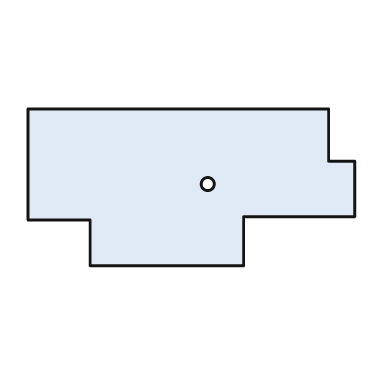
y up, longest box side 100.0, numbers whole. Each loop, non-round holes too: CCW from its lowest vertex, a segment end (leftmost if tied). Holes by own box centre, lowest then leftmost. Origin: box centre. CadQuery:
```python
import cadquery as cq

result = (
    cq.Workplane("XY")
    .moveTo(-31.0, -24.0)
    .lineTo(16.0, -24.0)
    .lineTo(16.0, -9.0)
    .lineTo(50.0, -9.0)
    .lineTo(50.0, 8.0)
    .lineTo(42.0, 8.0)
    .lineTo(42.0, 24.0)
    .lineTo(-50.0, 24.0)
    .lineTo(-50.0, -10.0)
    .lineTo(-31.0, -10.0)
    .close()
    .moveTo(5.0, 1.0)
    .circle(2.0)
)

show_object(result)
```